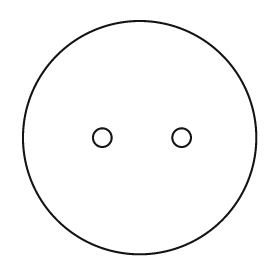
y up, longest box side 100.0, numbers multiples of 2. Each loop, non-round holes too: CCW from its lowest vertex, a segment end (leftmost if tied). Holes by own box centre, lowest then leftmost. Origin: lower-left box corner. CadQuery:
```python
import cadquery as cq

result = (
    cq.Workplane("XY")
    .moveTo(50.0, 50.0)
    .circle(50.0)
    .moveTo(34.0, 50.0)
    .circle(4.0)
    .moveTo(68.0, 50.0)
    .circle(4.0)
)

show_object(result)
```